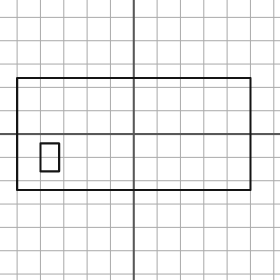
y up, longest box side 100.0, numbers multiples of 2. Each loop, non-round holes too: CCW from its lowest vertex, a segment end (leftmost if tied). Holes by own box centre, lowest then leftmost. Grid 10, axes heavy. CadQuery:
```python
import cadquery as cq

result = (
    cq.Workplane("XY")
    .moveTo(-50.0, -24.0)
    .lineTo(50.0, -24.0)
    .lineTo(50.0, 24.0)
    .lineTo(-50.0, 24.0)
    .close()
    .moveTo(-40.0, -16.0)
    .lineTo(-32.0, -16.0)
    .lineTo(-32.0, -4.0)
    .lineTo(-40.0, -4.0)
    .close()
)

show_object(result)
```